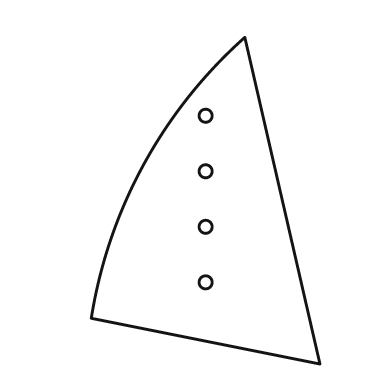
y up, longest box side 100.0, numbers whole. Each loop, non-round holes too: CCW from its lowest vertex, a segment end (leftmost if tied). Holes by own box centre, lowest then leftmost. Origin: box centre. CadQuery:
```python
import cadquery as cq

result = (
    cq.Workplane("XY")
    .moveTo(35.0, -50.0)
    .lineTo(12.0, 50.0)
    .threePointArc((-19.0, 11.0), (-35.0, -36.0))
    .close()
    .moveTo(0.0, -25.0)
    .circle(2.0)
    .moveTo(0.0, -8.0)
    .circle(2.0)
    .moveTo(0.0, 9.0)
    .circle(2.0)
    .moveTo(0.0, 26.0)
    .circle(2.0)
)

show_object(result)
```